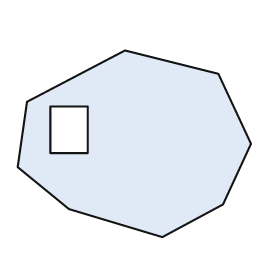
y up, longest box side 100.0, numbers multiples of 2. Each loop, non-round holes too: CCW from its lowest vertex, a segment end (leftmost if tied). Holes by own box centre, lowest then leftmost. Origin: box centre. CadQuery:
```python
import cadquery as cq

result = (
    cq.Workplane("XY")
    .moveTo(12.0, -40.0)
    .lineTo(38.0, -26.0)
    .lineTo(50.0, 0.0)
    .lineTo(36.0, 30.0)
    .lineTo(-4.0, 40.0)
    .lineTo(-46.0, 18.0)
    .lineTo(-50.0, -10.0)
    .lineTo(-28.0, -28.0)
    .close()
    .moveTo(-36.0, -4.0)
    .lineTo(-20.0, -4.0)
    .lineTo(-20.0, 16.0)
    .lineTo(-36.0, 16.0)
    .close()
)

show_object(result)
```